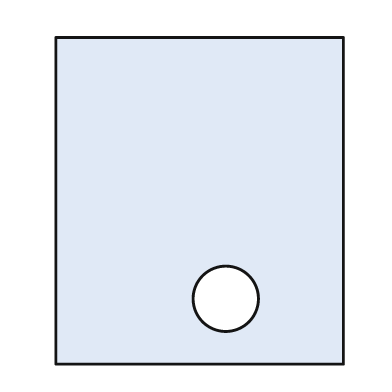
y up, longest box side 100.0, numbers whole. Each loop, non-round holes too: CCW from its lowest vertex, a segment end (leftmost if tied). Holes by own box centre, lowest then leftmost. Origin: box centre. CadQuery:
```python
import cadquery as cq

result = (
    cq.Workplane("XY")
    .moveTo(-44.0, -50.0)
    .lineTo(44.0, -50.0)
    .lineTo(44.0, 50.0)
    .lineTo(-44.0, 50.0)
    .close()
    .moveTo(8.0, -30.0)
    .circle(10.0)
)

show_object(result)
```